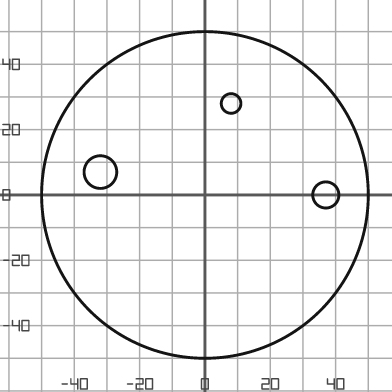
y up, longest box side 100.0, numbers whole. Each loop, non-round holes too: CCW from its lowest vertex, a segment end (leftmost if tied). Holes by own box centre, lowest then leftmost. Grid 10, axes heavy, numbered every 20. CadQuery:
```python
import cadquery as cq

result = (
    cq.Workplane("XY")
    .moveTo(0.0, 0.0)
    .circle(50.0)
    .moveTo(37.0, 0.0)
    .circle(4.0)
    .moveTo(-32.0, 7.0)
    .circle(5.0)
    .moveTo(8.0, 28.0)
    .circle(3.0)
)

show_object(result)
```